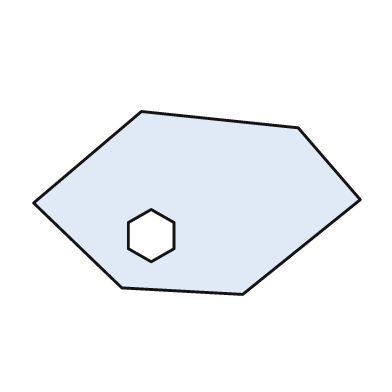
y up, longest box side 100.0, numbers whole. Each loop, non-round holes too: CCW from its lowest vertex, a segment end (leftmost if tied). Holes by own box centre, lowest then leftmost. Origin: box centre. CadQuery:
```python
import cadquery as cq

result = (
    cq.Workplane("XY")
    .moveTo(14.0, -28.0)
    .lineTo(50.0, 1.0)
    .lineTo(31.0, 23.0)
    .lineTo(-17.0, 28.0)
    .lineTo(-50.0, 0.0)
    .lineTo(-23.0, -26.0)
    .close()
    .moveTo(-14.0, -18.0)
    .lineTo(-7.0, -14.0)
    .lineTo(-7.0, -6.0)
    .lineTo(-14.0, -2.0)
    .lineTo(-21.0, -6.0)
    .lineTo(-21.0, -14.0)
    .close()
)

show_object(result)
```